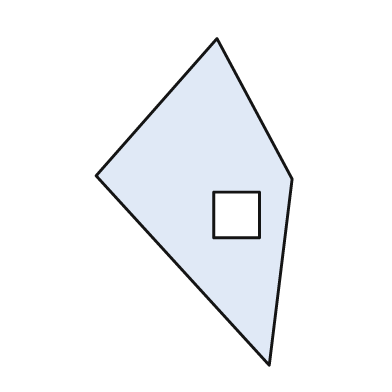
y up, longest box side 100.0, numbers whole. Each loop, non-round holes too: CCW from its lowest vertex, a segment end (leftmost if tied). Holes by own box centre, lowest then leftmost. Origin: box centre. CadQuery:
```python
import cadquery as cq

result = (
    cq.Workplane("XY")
    .moveTo(23.0, -50.0)
    .lineTo(30.0, 7.0)
    .lineTo(7.0, 50.0)
    .lineTo(-30.0, 8.0)
    .close()
    .moveTo(6.0, -11.0)
    .lineTo(20.0, -11.0)
    .lineTo(20.0, 3.0)
    .lineTo(6.0, 3.0)
    .close()
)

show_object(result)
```